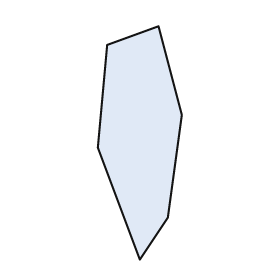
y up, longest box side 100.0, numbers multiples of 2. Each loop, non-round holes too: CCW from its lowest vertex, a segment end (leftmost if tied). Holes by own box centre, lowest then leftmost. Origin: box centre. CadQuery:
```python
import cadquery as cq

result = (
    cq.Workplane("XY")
    .moveTo(0.0, -50.0)
    .lineTo(12.0, -32.0)
    .lineTo(18.0, 12.0)
    .lineTo(8.0, 50.0)
    .lineTo(-14.0, 42.0)
    .lineTo(-18.0, -2.0)
    .close()
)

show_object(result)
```